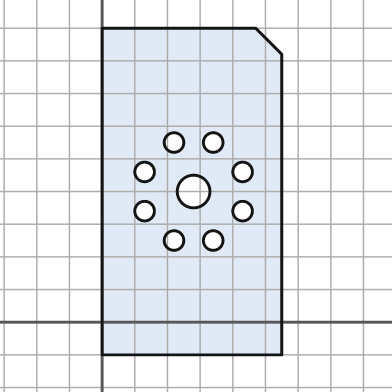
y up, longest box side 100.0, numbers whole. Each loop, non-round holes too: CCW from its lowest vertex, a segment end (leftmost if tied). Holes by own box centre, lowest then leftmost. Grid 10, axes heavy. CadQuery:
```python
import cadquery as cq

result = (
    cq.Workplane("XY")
    .moveTo(0.0, -10.0)
    .lineTo(55.0, -10.0)
    .lineTo(55.0, 82.0)
    .lineTo(47.0, 90.0)
    .lineTo(0.0, 90.0)
    .close()
    .moveTo(22.0, 25.0)
    .circle(3.0)
    .moveTo(34.0, 25.0)
    .circle(3.0)
    .moveTo(13.0, 34.0)
    .circle(3.0)
    .moveTo(43.0, 34.0)
    .circle(3.0)
    .moveTo(28.0, 40.0)
    .circle(5.0)
    .moveTo(13.0, 46.0)
    .circle(3.0)
    .moveTo(43.0, 46.0)
    .circle(3.0)
    .moveTo(22.0, 55.0)
    .circle(3.0)
    .moveTo(34.0, 55.0)
    .circle(3.0)
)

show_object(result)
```